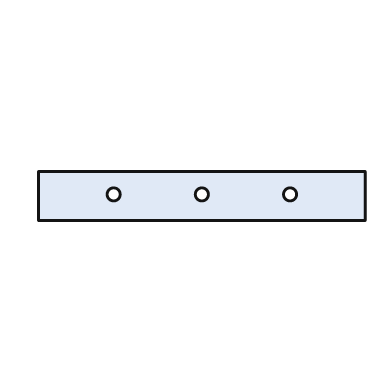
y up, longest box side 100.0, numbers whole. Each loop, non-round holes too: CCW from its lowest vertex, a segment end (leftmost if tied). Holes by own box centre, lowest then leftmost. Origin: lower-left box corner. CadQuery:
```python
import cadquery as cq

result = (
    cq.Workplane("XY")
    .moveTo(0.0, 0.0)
    .lineTo(100.0, 0.0)
    .lineTo(100.0, 15.0)
    .lineTo(0.0, 15.0)
    .close()
    .moveTo(23.0, 8.0)
    .circle(2.0)
    .moveTo(50.0, 8.0)
    .circle(2.0)
    .moveTo(77.0, 8.0)
    .circle(2.0)
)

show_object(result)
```